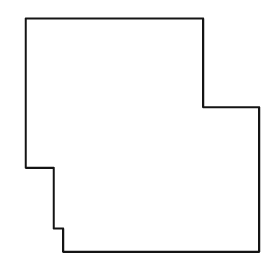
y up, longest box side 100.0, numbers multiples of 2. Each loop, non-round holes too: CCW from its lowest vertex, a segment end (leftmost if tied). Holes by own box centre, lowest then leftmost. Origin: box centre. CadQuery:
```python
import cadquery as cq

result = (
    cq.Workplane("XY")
    .moveTo(-34.0, -50.0)
    .lineTo(50.0, -50.0)
    .lineTo(50.0, 12.0)
    .lineTo(26.0, 12.0)
    .lineTo(26.0, 50.0)
    .lineTo(-50.0, 50.0)
    .lineTo(-50.0, -14.0)
    .lineTo(-38.0, -14.0)
    .lineTo(-38.0, -40.0)
    .lineTo(-34.0, -40.0)
    .close()
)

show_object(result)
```